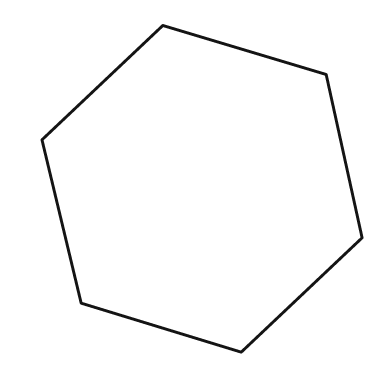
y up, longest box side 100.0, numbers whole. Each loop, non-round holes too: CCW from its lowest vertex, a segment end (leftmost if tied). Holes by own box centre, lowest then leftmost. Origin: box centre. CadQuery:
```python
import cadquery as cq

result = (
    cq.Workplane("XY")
    .moveTo(12.0, -50.0)
    .lineTo(49.0, -15.0)
    .lineTo(38.0, 35.0)
    .lineTo(-12.0, 50.0)
    .lineTo(-49.0, 15.0)
    .lineTo(-37.0, -35.0)
    .close()
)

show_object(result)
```